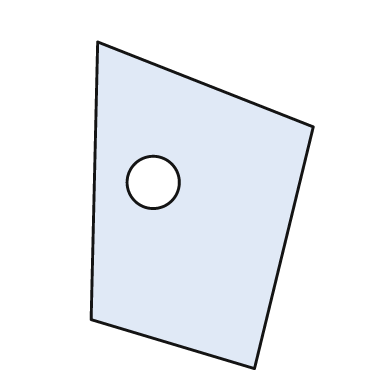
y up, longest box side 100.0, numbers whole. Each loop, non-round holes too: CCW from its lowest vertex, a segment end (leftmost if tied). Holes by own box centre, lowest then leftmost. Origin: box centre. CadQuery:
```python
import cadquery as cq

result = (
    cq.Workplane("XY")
    .moveTo(16.0, -50.0)
    .lineTo(34.0, 24.0)
    .lineTo(-32.0, 50.0)
    .lineTo(-34.0, -35.0)
    .close()
    .moveTo(-15.0, 7.0)
    .circle(8.0)
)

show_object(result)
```